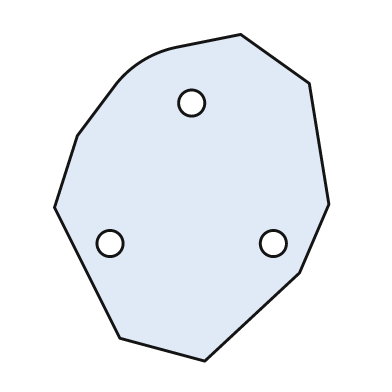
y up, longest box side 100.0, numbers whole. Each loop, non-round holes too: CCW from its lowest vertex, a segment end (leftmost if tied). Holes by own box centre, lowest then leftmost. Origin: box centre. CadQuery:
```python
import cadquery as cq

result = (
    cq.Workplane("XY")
    .moveTo(4.0, -50.0)
    .lineTo(33.0, -23.0)
    .lineTo(42.0, -2.0)
    .lineTo(36.0, 35.0)
    .lineTo(15.0, 50.0)
    .lineTo(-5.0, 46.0)
    .threePointArc((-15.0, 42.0), (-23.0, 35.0))
    .lineTo(-35.0, 19.0)
    .lineTo(-42.0, -3.0)
    .lineTo(-22.0, -43.0)
    .close()
    .moveTo(-25.0, -14.0)
    .circle(4.0)
    .moveTo(25.0, -14.0)
    .circle(4.0)
    .moveTo(0.0, 29.0)
    .circle(4.0)
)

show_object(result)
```